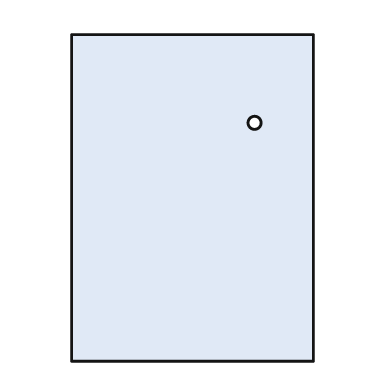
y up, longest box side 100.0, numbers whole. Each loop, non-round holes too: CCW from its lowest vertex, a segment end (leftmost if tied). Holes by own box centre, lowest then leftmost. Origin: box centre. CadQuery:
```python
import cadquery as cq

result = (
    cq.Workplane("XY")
    .moveTo(-37.0, -50.0)
    .lineTo(37.0, -50.0)
    .lineTo(37.0, 50.0)
    .lineTo(-37.0, 50.0)
    .close()
    .moveTo(19.0, 23.0)
    .circle(2.0)
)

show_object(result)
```